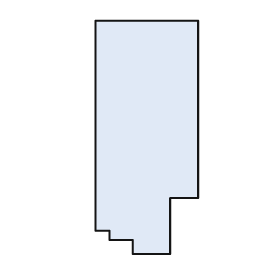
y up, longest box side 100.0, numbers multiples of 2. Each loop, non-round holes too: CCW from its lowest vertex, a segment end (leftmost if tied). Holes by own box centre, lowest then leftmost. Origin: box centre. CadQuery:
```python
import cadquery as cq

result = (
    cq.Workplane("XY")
    .moveTo(-6.0, -50.0)
    .lineTo(10.0, -50.0)
    .lineTo(10.0, -26.0)
    .lineTo(22.0, -26.0)
    .lineTo(22.0, 50.0)
    .lineTo(-22.0, 50.0)
    .lineTo(-22.0, -40.0)
    .lineTo(-16.0, -40.0)
    .lineTo(-16.0, -44.0)
    .lineTo(-6.0, -44.0)
    .close()
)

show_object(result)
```